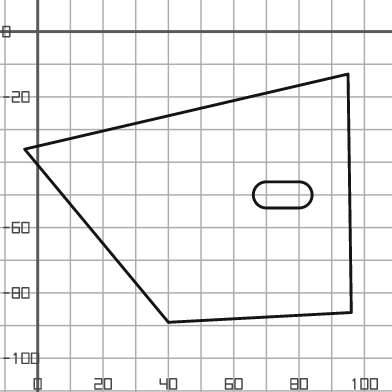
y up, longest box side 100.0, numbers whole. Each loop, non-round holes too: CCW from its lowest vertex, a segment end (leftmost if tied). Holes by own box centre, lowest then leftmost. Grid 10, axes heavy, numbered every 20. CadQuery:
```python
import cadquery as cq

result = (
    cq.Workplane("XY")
    .moveTo(40.0, -89.0)
    .lineTo(96.0, -86.0)
    .lineTo(95.0, -13.0)
    .lineTo(-4.0, -36.0)
    .close()
    .moveTo(70.0, -54.0)
    .lineTo(80.0, -54.0)
    .threePointArc((84.0, -50.0), (80.0, -46.0))
    .lineTo(70.0, -46.0)
    .threePointArc((66.0, -50.0), (70.0, -54.0))
    .close()
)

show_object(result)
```